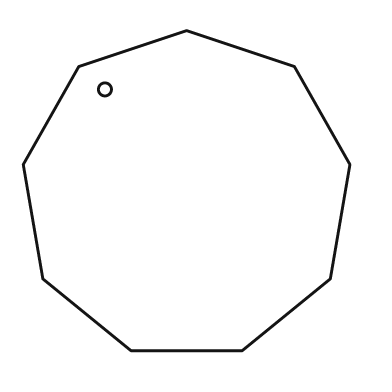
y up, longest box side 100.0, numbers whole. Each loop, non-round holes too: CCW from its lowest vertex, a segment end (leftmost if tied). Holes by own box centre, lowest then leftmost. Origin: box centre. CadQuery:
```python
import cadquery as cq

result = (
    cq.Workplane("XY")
    .moveTo(-17.0, -49.0)
    .lineTo(17.0, -49.0)
    .lineTo(44.0, -27.0)
    .lineTo(50.0, 8.0)
    .lineTo(33.0, 38.0)
    .lineTo(0.0, 49.0)
    .lineTo(-33.0, 38.0)
    .lineTo(-50.0, 8.0)
    .lineTo(-44.0, -27.0)
    .close()
    .moveTo(-25.0, 31.0)
    .circle(2.0)
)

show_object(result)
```